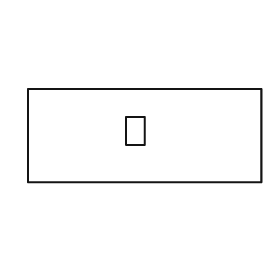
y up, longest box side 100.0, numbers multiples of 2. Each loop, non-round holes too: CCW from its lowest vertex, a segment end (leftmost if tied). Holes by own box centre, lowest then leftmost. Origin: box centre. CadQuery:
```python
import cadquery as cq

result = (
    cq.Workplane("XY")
    .moveTo(-50.0, -20.0)
    .lineTo(50.0, -20.0)
    .lineTo(50.0, 20.0)
    .lineTo(-50.0, 20.0)
    .close()
    .moveTo(-8.0, -4.0)
    .lineTo(0.0, -4.0)
    .lineTo(0.0, 8.0)
    .lineTo(-8.0, 8.0)
    .close()
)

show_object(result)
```